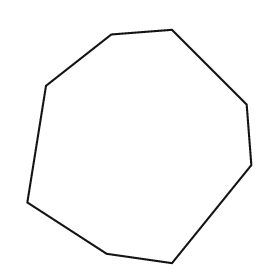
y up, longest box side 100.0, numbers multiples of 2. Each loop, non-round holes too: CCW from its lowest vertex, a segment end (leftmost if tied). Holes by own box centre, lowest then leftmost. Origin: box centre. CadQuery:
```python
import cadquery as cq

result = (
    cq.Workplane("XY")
    .moveTo(14.0, -50.0)
    .lineTo(48.0, -8.0)
    .lineTo(46.0, 18.0)
    .lineTo(14.0, 50.0)
    .lineTo(-12.0, 48.0)
    .lineTo(-40.0, 26.0)
    .lineTo(-48.0, -24.0)
    .lineTo(-14.0, -46.0)
    .close()
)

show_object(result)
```